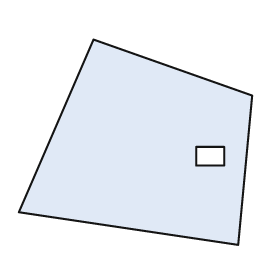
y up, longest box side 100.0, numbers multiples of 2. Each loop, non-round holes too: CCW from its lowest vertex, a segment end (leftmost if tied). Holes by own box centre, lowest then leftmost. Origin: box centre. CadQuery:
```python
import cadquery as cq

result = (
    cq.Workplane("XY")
    .moveTo(44.0, -44.0)
    .lineTo(50.0, 20.0)
    .lineTo(-18.0, 44.0)
    .lineTo(-50.0, -30.0)
    .close()
    .moveTo(26.0, -10.0)
    .lineTo(38.0, -10.0)
    .lineTo(38.0, -2.0)
    .lineTo(26.0, -2.0)
    .close()
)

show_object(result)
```